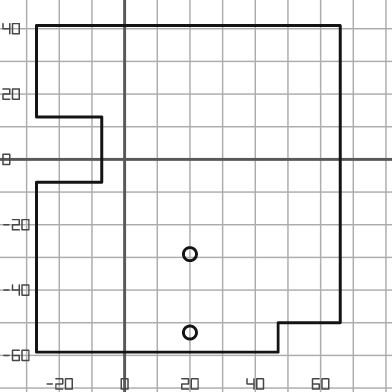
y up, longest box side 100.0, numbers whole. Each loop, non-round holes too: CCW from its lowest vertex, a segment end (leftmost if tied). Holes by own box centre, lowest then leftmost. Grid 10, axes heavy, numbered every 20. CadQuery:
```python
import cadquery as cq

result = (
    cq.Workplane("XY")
    .moveTo(-27.0, -59.0)
    .lineTo(47.0, -59.0)
    .lineTo(47.0, -50.0)
    .lineTo(66.0, -50.0)
    .lineTo(66.0, 41.0)
    .lineTo(-27.0, 41.0)
    .lineTo(-27.0, 13.0)
    .lineTo(-7.0, 13.0)
    .lineTo(-7.0, -7.0)
    .lineTo(-27.0, -7.0)
    .close()
    .moveTo(20.0, -53.0)
    .circle(2.0)
    .moveTo(20.0, -29.0)
    .circle(2.0)
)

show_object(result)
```